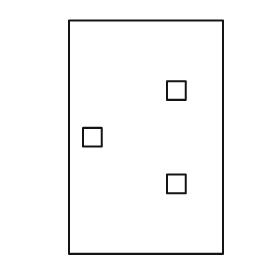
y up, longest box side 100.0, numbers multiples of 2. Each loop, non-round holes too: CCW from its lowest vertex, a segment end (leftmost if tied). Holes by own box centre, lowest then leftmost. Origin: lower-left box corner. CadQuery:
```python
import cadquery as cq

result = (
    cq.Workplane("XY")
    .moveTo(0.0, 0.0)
    .lineTo(66.0, 0.0)
    .lineTo(66.0, 100.0)
    .lineTo(0.0, 100.0)
    .close()
    .moveTo(42.0, 26.0)
    .lineTo(50.0, 26.0)
    .lineTo(50.0, 34.0)
    .lineTo(42.0, 34.0)
    .close()
    .moveTo(6.0, 46.0)
    .lineTo(14.0, 46.0)
    .lineTo(14.0, 54.0)
    .lineTo(6.0, 54.0)
    .close()
    .moveTo(42.0, 66.0)
    .lineTo(50.0, 66.0)
    .lineTo(50.0, 74.0)
    .lineTo(42.0, 74.0)
    .close()
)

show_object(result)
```